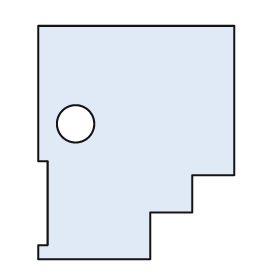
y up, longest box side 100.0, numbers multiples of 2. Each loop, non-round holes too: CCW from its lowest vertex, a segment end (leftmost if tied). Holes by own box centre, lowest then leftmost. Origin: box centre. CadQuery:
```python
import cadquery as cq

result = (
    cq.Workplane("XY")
    .moveTo(-42.0, -50.0)
    .lineTo(6.0, -50.0)
    .lineTo(6.0, -30.0)
    .lineTo(24.0, -30.0)
    .lineTo(24.0, -14.0)
    .lineTo(42.0, -14.0)
    .lineTo(42.0, 50.0)
    .lineTo(-42.0, 50.0)
    .lineTo(-42.0, -8.0)
    .lineTo(-38.0, -8.0)
    .lineTo(-38.0, -44.0)
    .lineTo(-42.0, -44.0)
    .close()
    .moveTo(-26.0, 8.0)
    .circle(8.0)
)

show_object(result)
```